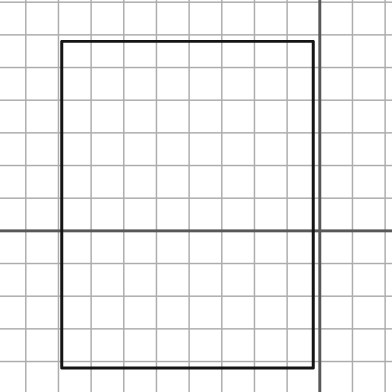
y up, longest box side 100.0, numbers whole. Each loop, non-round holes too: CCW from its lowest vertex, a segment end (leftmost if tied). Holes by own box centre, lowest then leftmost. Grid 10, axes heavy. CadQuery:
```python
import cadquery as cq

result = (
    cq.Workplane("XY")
    .moveTo(-79.0, -42.0)
    .lineTo(-2.0, -42.0)
    .lineTo(-2.0, 58.0)
    .lineTo(-79.0, 58.0)
    .close()
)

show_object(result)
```